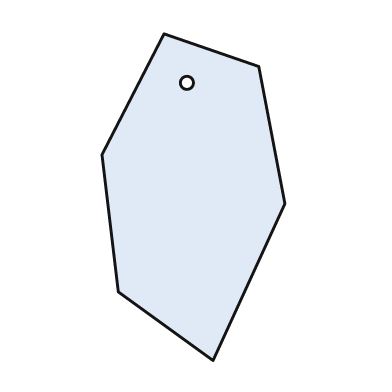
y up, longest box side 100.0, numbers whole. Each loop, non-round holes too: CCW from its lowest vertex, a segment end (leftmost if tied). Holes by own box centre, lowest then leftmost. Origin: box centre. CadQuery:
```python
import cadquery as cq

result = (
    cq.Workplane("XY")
    .moveTo(6.0, -50.0)
    .lineTo(28.0, -2.0)
    .lineTo(20.0, 40.0)
    .lineTo(-9.0, 50.0)
    .lineTo(-28.0, 13.0)
    .lineTo(-23.0, -29.0)
    .close()
    .moveTo(-2.0, 35.0)
    .circle(2.0)
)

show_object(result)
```